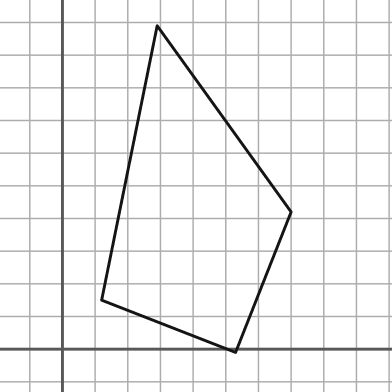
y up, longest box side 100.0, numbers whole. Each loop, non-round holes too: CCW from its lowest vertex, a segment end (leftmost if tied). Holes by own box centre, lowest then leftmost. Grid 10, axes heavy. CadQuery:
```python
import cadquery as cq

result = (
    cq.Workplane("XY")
    .moveTo(53.0, -1.0)
    .lineTo(70.0, 42.0)
    .lineTo(29.0, 99.0)
    .lineTo(12.0, 15.0)
    .close()
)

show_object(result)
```